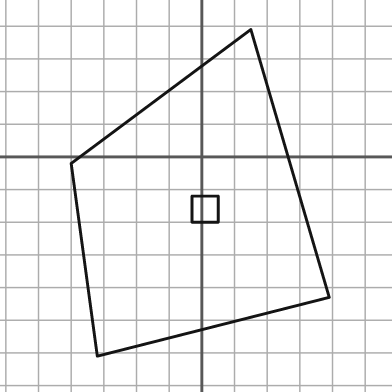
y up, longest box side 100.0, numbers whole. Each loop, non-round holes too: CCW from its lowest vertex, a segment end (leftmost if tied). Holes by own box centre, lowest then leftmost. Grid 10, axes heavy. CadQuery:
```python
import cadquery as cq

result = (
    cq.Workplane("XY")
    .moveTo(-32.0, -61.0)
    .lineTo(39.0, -43.0)
    .lineTo(15.0, 39.0)
    .lineTo(-40.0, -2.0)
    .close()
    .moveTo(-3.0, -20.0)
    .lineTo(5.0, -20.0)
    .lineTo(5.0, -12.0)
    .lineTo(-3.0, -12.0)
    .close()
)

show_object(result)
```